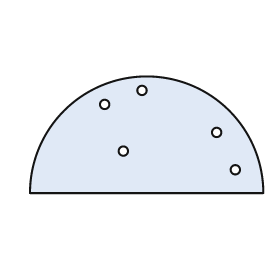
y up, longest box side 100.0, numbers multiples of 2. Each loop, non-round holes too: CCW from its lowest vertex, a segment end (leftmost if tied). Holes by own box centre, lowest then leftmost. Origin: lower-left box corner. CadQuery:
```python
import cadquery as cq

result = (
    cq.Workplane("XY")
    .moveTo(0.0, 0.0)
    .lineTo(100.0, 0.0)
    .threePointArc((50.0, 50.0), (0.0, 0.0))
    .close()
    .moveTo(88.0, 10.0)
    .circle(2.0)
    .moveTo(40.0, 18.0)
    .circle(2.0)
    .moveTo(80.0, 26.0)
    .circle(2.0)
    .moveTo(32.0, 38.0)
    .circle(2.0)
    .moveTo(48.0, 44.0)
    .circle(2.0)
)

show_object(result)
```